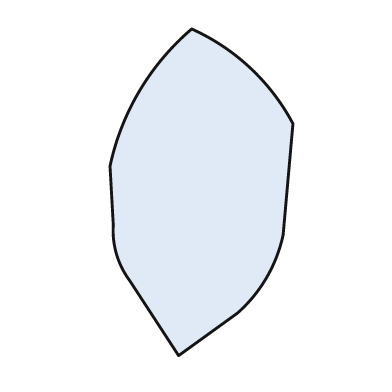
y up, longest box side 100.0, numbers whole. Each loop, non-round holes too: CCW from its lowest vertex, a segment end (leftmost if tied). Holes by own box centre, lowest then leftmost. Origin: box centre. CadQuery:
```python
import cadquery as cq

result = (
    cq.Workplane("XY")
    .moveTo(-7.0, -50.0)
    .lineTo(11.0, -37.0)
    .threePointArc((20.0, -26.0), (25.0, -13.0))
    .lineTo(28.0, 21.0)
    .threePointArc((15.0, 38.0), (-3.0, 50.0))
    .threePointArc((-19.0, 31.0), (-28.0, 8.0))
    .lineTo(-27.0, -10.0)
    .threePointArc((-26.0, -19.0), (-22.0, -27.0))
    .close()
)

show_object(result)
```